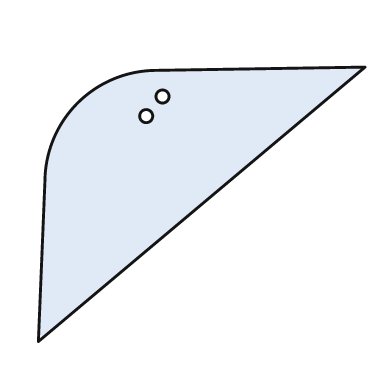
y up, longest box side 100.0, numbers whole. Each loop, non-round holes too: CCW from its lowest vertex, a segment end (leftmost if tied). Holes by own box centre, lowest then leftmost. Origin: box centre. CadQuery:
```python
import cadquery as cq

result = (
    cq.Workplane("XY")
    .moveTo(-50.0, -42.0)
    .lineTo(50.0, 42.0)
    .lineTo(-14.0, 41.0)
    .threePointArc((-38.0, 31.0), (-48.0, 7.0))
    .close()
    .moveTo(-17.0, 27.0)
    .circle(2.0)
    .moveTo(-12.0, 33.0)
    .circle(2.0)
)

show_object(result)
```